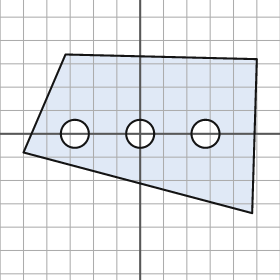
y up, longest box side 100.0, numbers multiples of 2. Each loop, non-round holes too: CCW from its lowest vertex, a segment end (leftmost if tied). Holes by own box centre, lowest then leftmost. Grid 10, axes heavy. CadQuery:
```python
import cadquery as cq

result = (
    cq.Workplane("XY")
    .moveTo(48.0, -34.0)
    .lineTo(50.0, 32.0)
    .lineTo(-32.0, 34.0)
    .lineTo(-50.0, -8.0)
    .close()
    .moveTo(-28.0, 0.0)
    .circle(6.0)
    .moveTo(0.0, 0.0)
    .circle(6.0)
    .moveTo(28.0, 0.0)
    .circle(6.0)
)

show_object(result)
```